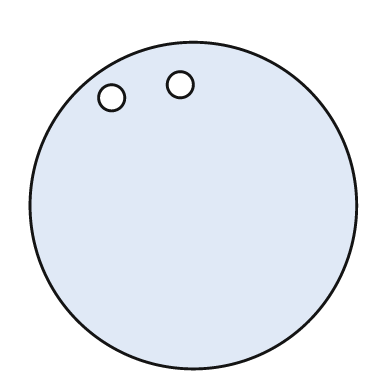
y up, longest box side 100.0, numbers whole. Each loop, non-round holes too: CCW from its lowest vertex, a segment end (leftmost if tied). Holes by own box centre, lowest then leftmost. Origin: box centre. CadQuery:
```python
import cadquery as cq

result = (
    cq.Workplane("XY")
    .moveTo(0.0, 0.0)
    .circle(50.0)
    .moveTo(-25.0, 33.0)
    .circle(4.0)
    .moveTo(-4.0, 37.0)
    .circle(4.0)
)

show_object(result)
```